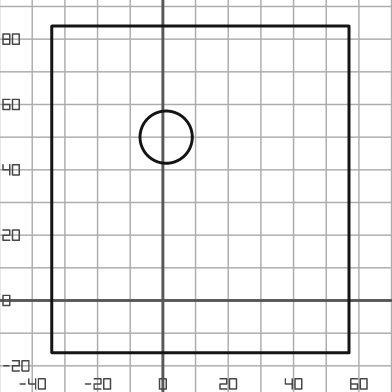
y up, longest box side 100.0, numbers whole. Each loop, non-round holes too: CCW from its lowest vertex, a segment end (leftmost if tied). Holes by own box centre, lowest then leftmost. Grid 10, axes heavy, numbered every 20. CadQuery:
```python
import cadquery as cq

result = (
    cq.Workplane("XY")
    .moveTo(-34.0, -16.0)
    .lineTo(57.0, -16.0)
    .lineTo(57.0, 84.0)
    .lineTo(-34.0, 84.0)
    .close()
    .moveTo(1.0, 50.0)
    .circle(8.0)
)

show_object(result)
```